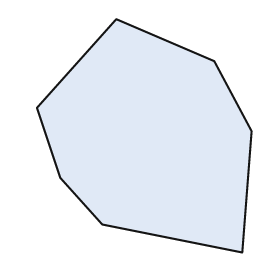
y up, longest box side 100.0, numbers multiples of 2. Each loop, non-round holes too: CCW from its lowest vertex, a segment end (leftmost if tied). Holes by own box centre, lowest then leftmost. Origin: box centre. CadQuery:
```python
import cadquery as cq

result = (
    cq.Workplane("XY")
    .moveTo(42.0, -50.0)
    .lineTo(46.0, 2.0)
    .lineTo(30.0, 32.0)
    .lineTo(-12.0, 50.0)
    .lineTo(-46.0, 12.0)
    .lineTo(-36.0, -18.0)
    .lineTo(-18.0, -38.0)
    .close()
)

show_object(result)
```